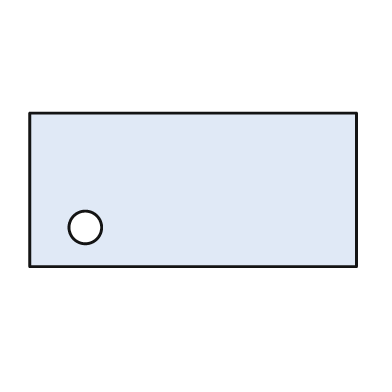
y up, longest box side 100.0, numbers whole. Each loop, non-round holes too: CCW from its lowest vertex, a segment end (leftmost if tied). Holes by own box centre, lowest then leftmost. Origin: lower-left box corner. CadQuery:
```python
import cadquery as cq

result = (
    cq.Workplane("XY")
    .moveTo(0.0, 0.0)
    .lineTo(100.0, 0.0)
    .lineTo(100.0, 47.0)
    .lineTo(0.0, 47.0)
    .close()
    .moveTo(17.0, 12.0)
    .circle(5.0)
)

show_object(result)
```